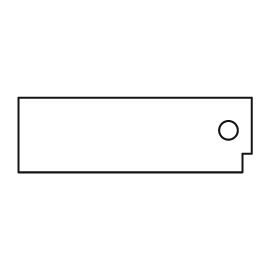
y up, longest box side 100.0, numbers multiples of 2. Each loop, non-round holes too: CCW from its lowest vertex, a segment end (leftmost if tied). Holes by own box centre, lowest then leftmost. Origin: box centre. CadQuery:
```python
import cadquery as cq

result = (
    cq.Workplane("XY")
    .moveTo(-50.0, -16.0)
    .lineTo(46.0, -16.0)
    .lineTo(46.0, -8.0)
    .lineTo(50.0, -8.0)
    .lineTo(50.0, 16.0)
    .lineTo(-50.0, 16.0)
    .close()
    .moveTo(40.0, 2.0)
    .circle(4.0)
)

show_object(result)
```